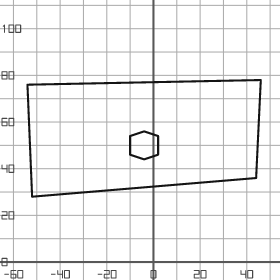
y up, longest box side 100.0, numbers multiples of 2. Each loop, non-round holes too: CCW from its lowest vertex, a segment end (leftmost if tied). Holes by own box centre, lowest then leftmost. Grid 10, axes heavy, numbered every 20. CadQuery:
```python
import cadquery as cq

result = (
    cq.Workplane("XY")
    .moveTo(-52.0, 28.0)
    .lineTo(44.0, 36.0)
    .lineTo(46.0, 78.0)
    .lineTo(-54.0, 76.0)
    .close()
    .moveTo(-4.0, 44.0)
    .lineTo(2.0, 46.0)
    .lineTo(2.0, 54.0)
    .lineTo(-4.0, 56.0)
    .lineTo(-10.0, 54.0)
    .lineTo(-10.0, 46.0)
    .close()
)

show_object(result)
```